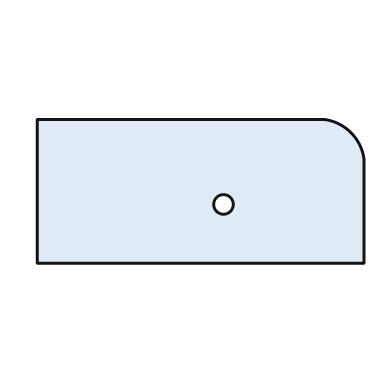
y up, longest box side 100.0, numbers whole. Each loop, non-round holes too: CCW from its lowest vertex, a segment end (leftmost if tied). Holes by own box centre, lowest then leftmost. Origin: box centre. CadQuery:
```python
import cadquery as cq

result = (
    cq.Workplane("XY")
    .moveTo(-50.0, -22.0)
    .lineTo(50.0, -22.0)
    .lineTo(50.0, 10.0)
    .threePointArc((46.0, 18.0), (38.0, 22.0))
    .lineTo(-50.0, 22.0)
    .close()
    .moveTo(7.0, -4.0)
    .circle(3.0)
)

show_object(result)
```